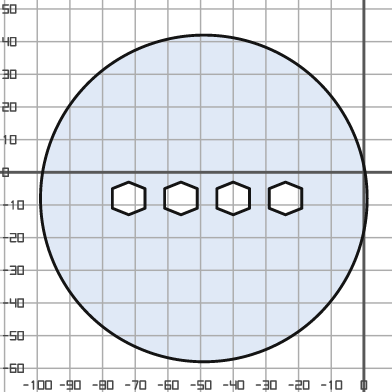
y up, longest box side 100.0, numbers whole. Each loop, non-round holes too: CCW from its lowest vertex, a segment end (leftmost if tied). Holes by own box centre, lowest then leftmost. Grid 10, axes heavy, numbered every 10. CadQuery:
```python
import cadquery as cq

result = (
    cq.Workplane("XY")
    .moveTo(-49.0, -8.0)
    .circle(50.0)
    .moveTo(-72.0, -13.0)
    .lineTo(-67.0, -11.0)
    .lineTo(-67.0, -5.0)
    .lineTo(-72.0, -3.0)
    .lineTo(-77.0, -5.0)
    .lineTo(-77.0, -11.0)
    .close()
    .moveTo(-56.0, -13.0)
    .lineTo(-51.0, -11.0)
    .lineTo(-51.0, -5.0)
    .lineTo(-56.0, -3.0)
    .lineTo(-61.0, -5.0)
    .lineTo(-61.0, -11.0)
    .close()
    .moveTo(-40.0, -13.0)
    .lineTo(-35.0, -11.0)
    .lineTo(-35.0, -5.0)
    .lineTo(-40.0, -3.0)
    .lineTo(-45.0, -5.0)
    .lineTo(-45.0, -11.0)
    .close()
    .moveTo(-24.0, -13.0)
    .lineTo(-19.0, -11.0)
    .lineTo(-19.0, -5.0)
    .lineTo(-24.0, -3.0)
    .lineTo(-29.0, -5.0)
    .lineTo(-29.0, -11.0)
    .close()
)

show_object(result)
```